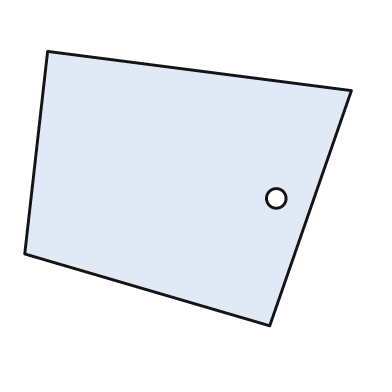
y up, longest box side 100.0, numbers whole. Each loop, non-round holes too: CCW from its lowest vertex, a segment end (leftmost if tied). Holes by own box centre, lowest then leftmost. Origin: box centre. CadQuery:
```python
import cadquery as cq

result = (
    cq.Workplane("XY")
    .moveTo(25.0, -42.0)
    .lineTo(50.0, 30.0)
    .lineTo(-43.0, 42.0)
    .lineTo(-50.0, -20.0)
    .close()
    .moveTo(27.0, -3.0)
    .circle(3.0)
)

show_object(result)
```